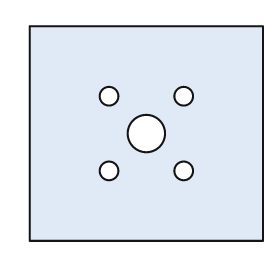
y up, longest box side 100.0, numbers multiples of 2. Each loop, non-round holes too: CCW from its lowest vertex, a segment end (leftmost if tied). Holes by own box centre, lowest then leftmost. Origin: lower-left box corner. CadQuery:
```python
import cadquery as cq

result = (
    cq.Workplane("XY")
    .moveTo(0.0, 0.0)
    .lineTo(100.0, 0.0)
    .lineTo(100.0, 92.0)
    .lineTo(0.0, 92.0)
    .close()
    .moveTo(34.0, 30.0)
    .circle(4.0)
    .moveTo(66.0, 30.0)
    .circle(4.0)
    .moveTo(50.0, 46.0)
    .circle(8.0)
    .moveTo(34.0, 62.0)
    .circle(4.0)
    .moveTo(66.0, 62.0)
    .circle(4.0)
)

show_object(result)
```